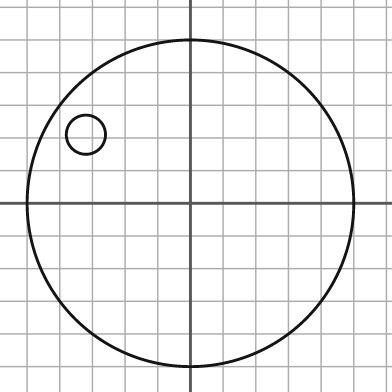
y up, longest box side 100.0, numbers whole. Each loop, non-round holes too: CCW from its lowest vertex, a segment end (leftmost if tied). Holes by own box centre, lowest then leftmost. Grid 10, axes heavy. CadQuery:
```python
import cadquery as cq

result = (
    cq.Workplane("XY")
    .moveTo(0.0, 0.0)
    .circle(50.0)
    .moveTo(-32.0, 21.0)
    .circle(6.0)
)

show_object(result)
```